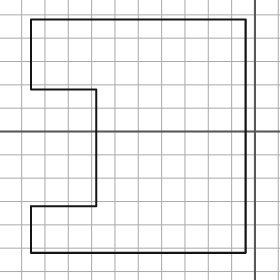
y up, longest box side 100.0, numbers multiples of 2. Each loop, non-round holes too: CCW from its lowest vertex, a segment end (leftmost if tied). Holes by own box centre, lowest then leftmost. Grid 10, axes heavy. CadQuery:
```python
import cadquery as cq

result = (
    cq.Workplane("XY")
    .moveTo(-96.0, -52.0)
    .lineTo(-4.0, -52.0)
    .lineTo(-4.0, 48.0)
    .lineTo(-96.0, 48.0)
    .lineTo(-96.0, 18.0)
    .lineTo(-68.0, 18.0)
    .lineTo(-68.0, -32.0)
    .lineTo(-96.0, -32.0)
    .close()
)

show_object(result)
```